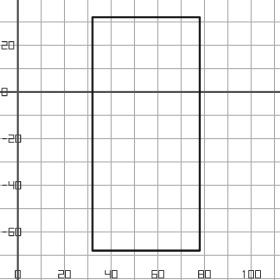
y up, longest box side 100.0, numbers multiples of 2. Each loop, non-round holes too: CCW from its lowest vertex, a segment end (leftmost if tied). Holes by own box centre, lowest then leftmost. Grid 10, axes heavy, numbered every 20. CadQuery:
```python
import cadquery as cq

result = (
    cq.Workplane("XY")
    .moveTo(32.0, -68.0)
    .lineTo(78.0, -68.0)
    .lineTo(78.0, 32.0)
    .lineTo(32.0, 32.0)
    .close()
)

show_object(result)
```